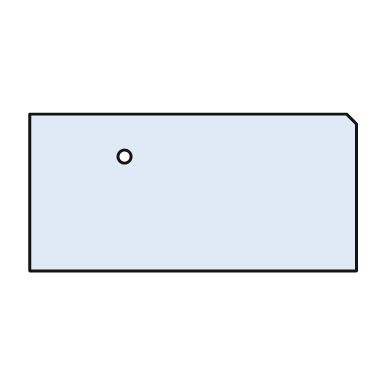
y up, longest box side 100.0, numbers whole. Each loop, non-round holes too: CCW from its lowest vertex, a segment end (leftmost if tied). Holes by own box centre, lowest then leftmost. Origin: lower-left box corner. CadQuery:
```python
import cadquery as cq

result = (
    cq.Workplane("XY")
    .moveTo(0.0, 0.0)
    .lineTo(100.0, 0.0)
    .lineTo(100.0, 45.0)
    .lineTo(97.0, 48.0)
    .lineTo(0.0, 48.0)
    .close()
    .moveTo(29.0, 35.0)
    .circle(2.0)
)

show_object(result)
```